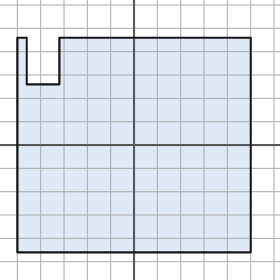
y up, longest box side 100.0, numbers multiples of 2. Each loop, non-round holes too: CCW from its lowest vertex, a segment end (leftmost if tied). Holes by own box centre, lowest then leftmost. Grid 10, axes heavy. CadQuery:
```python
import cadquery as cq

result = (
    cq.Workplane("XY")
    .moveTo(-50.0, -46.0)
    .lineTo(50.0, -46.0)
    .lineTo(50.0, 46.0)
    .lineTo(-32.0, 46.0)
    .lineTo(-32.0, 26.0)
    .lineTo(-46.0, 26.0)
    .lineTo(-46.0, 46.0)
    .lineTo(-50.0, 46.0)
    .close()
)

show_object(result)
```